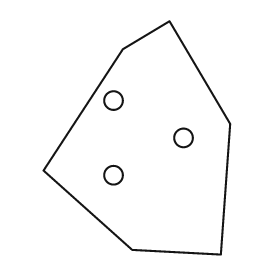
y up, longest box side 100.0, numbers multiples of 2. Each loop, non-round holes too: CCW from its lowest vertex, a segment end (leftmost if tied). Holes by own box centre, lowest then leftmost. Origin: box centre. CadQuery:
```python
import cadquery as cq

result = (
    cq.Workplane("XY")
    .moveTo(36.0, -50.0)
    .lineTo(40.0, 6.0)
    .lineTo(14.0, 50.0)
    .lineTo(-6.0, 38.0)
    .lineTo(-40.0, -14.0)
    .lineTo(-2.0, -48.0)
    .close()
    .moveTo(-10.0, -16.0)
    .circle(4.0)
    .moveTo(20.0, 0.0)
    .circle(4.0)
    .moveTo(-10.0, 16.0)
    .circle(4.0)
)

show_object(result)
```